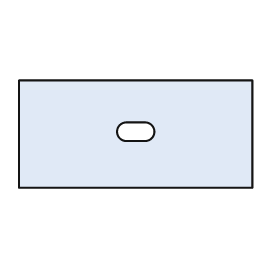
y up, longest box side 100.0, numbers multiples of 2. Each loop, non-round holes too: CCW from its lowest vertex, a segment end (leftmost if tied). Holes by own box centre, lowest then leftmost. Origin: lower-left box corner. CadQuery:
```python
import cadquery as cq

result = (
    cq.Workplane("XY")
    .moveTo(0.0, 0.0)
    .lineTo(100.0, 0.0)
    .lineTo(100.0, 46.0)
    .lineTo(0.0, 46.0)
    .close()
    .moveTo(46.0, 20.0)
    .lineTo(54.0, 20.0)
    .threePointArc((58.0, 24.0), (54.0, 28.0))
    .lineTo(46.0, 28.0)
    .threePointArc((42.0, 24.0), (46.0, 20.0))
    .close()
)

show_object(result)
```